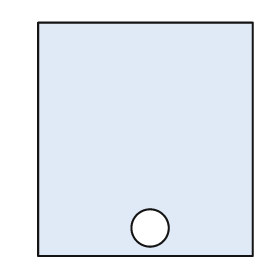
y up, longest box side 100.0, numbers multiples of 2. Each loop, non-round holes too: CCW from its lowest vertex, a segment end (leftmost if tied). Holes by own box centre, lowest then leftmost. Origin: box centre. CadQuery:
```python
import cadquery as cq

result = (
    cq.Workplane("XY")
    .moveTo(-46.0, -50.0)
    .lineTo(46.0, -50.0)
    .lineTo(46.0, 50.0)
    .lineTo(-46.0, 50.0)
    .close()
    .moveTo(2.0, -38.0)
    .circle(8.0)
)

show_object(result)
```